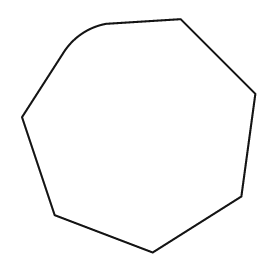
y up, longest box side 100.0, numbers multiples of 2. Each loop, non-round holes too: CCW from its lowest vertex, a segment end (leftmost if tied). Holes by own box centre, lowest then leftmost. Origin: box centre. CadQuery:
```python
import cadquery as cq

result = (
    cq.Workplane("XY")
    .moveTo(6.0, -50.0)
    .lineTo(44.0, -26.0)
    .lineTo(50.0, 18.0)
    .lineTo(18.0, 50.0)
    .lineTo(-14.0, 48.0)
    .threePointArc((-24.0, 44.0), (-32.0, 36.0))
    .lineTo(-50.0, 8.0)
    .lineTo(-36.0, -34.0)
    .close()
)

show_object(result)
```